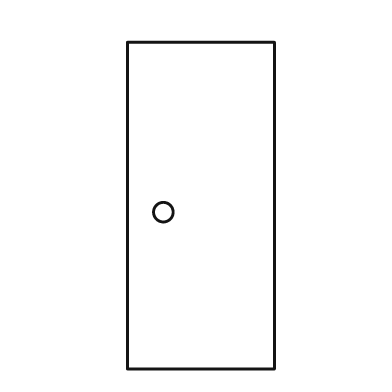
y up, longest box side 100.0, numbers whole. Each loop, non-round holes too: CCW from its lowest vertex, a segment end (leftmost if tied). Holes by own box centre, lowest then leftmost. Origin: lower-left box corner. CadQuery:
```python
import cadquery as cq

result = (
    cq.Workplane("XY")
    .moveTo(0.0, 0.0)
    .lineTo(45.0, 0.0)
    .lineTo(45.0, 100.0)
    .lineTo(0.0, 100.0)
    .close()
    .moveTo(11.0, 48.0)
    .circle(3.0)
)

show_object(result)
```